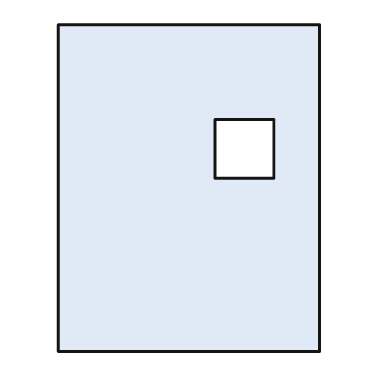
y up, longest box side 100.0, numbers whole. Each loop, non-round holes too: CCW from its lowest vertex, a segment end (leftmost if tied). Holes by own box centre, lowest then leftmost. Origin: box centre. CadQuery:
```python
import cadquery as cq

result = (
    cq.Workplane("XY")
    .moveTo(-40.0, -50.0)
    .lineTo(40.0, -50.0)
    .lineTo(40.0, 50.0)
    .lineTo(-40.0, 50.0)
    .close()
    .moveTo(8.0, 3.0)
    .lineTo(26.0, 3.0)
    .lineTo(26.0, 21.0)
    .lineTo(8.0, 21.0)
    .close()
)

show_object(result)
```